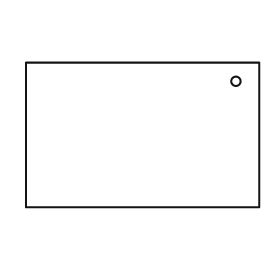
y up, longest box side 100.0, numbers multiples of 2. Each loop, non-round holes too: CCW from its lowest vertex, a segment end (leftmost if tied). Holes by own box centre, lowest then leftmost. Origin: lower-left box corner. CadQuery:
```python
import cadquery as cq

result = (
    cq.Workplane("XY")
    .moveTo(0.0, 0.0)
    .lineTo(100.0, 0.0)
    .lineTo(100.0, 62.0)
    .lineTo(0.0, 62.0)
    .close()
    .moveTo(90.0, 54.0)
    .circle(2.0)
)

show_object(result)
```